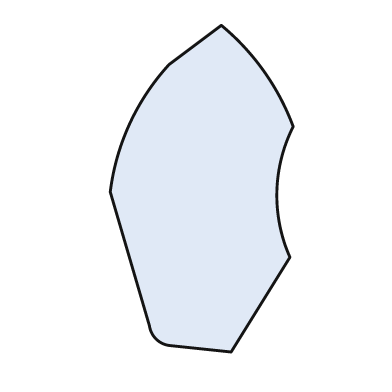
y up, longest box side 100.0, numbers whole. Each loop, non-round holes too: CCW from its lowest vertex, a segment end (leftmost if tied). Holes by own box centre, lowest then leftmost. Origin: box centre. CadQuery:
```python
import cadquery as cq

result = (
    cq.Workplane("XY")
    .moveTo(9.0, -50.0)
    .lineTo(27.0, -21.0)
    .threePointArc((23.0, -1.0), (28.0, 19.0))
    .threePointArc((19.0, 36.0), (6.0, 50.0))
    .lineTo(-10.0, 38.0)
    .threePointArc((-22.0, 20.0), (-28.0, -1.0))
    .lineTo(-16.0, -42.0)
    .threePointArc((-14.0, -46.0), (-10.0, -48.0))
    .close()
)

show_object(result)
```